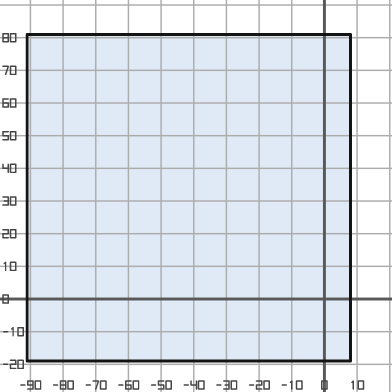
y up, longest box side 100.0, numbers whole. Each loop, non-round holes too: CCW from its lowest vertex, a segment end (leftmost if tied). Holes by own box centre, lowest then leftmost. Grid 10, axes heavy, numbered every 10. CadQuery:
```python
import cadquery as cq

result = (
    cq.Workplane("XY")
    .moveTo(-91.0, -19.0)
    .lineTo(8.0, -19.0)
    .lineTo(8.0, 81.0)
    .lineTo(-91.0, 81.0)
    .close()
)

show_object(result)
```